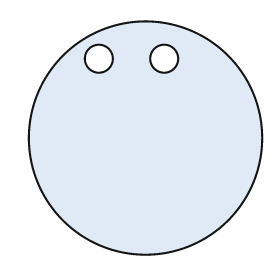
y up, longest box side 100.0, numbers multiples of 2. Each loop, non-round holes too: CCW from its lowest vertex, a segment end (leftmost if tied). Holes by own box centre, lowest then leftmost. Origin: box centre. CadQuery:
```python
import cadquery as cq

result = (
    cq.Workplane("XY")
    .moveTo(0.0, 0.0)
    .circle(50.0)
    .moveTo(-20.0, 34.0)
    .circle(6.0)
    .moveTo(8.0, 34.0)
    .circle(6.0)
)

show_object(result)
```